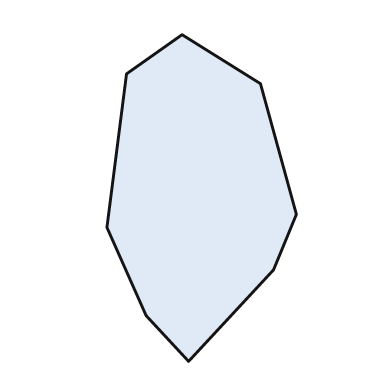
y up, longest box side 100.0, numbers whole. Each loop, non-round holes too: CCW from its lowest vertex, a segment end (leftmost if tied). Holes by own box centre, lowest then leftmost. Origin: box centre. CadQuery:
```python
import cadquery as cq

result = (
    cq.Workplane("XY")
    .moveTo(-4.0, -50.0)
    .lineTo(22.0, -22.0)
    .lineTo(29.0, -5.0)
    .lineTo(18.0, 35.0)
    .lineTo(-6.0, 50.0)
    .lineTo(-23.0, 38.0)
    .lineTo(-29.0, -9.0)
    .lineTo(-17.0, -36.0)
    .close()
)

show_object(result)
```